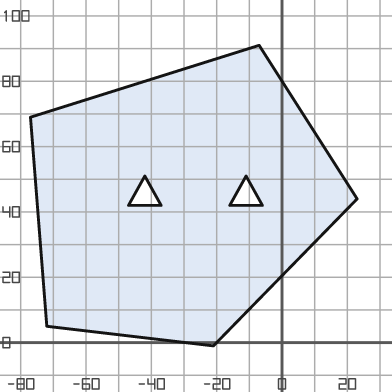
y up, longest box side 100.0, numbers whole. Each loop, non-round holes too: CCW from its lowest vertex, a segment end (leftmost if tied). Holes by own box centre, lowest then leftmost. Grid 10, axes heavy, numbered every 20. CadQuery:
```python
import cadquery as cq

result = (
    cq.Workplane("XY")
    .moveTo(-21.0, -1.0)
    .lineTo(23.0, 44.0)
    .lineTo(-7.0, 91.0)
    .lineTo(-77.0, 69.0)
    .lineTo(-72.0, 5.0)
    .close()
    .moveTo(-47.0, 42.0)
    .lineTo(-37.0, 42.0)
    .lineTo(-42.0, 51.0)
    .close()
    .moveTo(-16.0, 42.0)
    .lineTo(-6.0, 42.0)
    .lineTo(-11.0, 51.0)
    .close()
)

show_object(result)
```